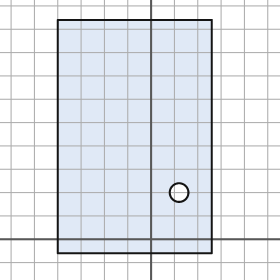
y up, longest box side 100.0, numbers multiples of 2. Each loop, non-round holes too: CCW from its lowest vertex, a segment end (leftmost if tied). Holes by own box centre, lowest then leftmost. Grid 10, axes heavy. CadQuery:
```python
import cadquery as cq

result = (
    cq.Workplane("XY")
    .moveTo(-40.0, -6.0)
    .lineTo(26.0, -6.0)
    .lineTo(26.0, 94.0)
    .lineTo(-40.0, 94.0)
    .close()
    .moveTo(12.0, 20.0)
    .circle(4.0)
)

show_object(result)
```